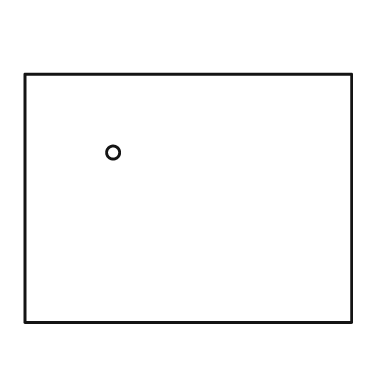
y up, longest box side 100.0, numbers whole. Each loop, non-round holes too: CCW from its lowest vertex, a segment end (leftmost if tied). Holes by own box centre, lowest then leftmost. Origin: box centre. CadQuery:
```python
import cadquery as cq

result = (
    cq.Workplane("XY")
    .moveTo(-50.0, -38.0)
    .lineTo(50.0, -38.0)
    .lineTo(50.0, 38.0)
    .lineTo(-50.0, 38.0)
    .close()
    .moveTo(-23.0, 14.0)
    .circle(2.0)
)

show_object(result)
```